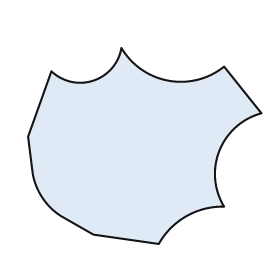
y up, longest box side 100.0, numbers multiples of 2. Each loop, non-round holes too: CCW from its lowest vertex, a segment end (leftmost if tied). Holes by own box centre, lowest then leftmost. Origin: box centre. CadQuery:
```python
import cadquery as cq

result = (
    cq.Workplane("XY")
    .moveTo(6.0, -42.0)
    .threePointArc((18.0, -30.0), (34.0, -26.0))
    .threePointArc((32.0, -2.0), (50.0, 14.0))
    .lineTo(34.0, 34.0)
    .threePointArc((10.0, 28.0), (-10.0, 42.0))
    .threePointArc((-22.0, 28.0), (-40.0, 32.0))
    .lineTo(-50.0, 4.0)
    .lineTo(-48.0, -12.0)
    .threePointArc((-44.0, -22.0), (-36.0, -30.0))
    .lineTo(-22.0, -38.0)
    .close()
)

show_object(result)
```